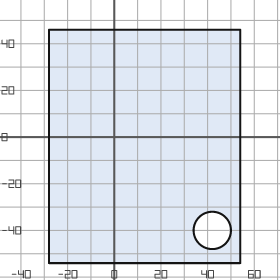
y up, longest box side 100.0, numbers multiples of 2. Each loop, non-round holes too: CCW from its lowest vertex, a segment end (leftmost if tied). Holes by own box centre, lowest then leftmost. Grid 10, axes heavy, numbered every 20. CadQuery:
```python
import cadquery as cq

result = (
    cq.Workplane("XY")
    .moveTo(-28.0, -54.0)
    .lineTo(54.0, -54.0)
    .lineTo(54.0, 46.0)
    .lineTo(-28.0, 46.0)
    .close()
    .moveTo(42.0, -40.0)
    .circle(8.0)
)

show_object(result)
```